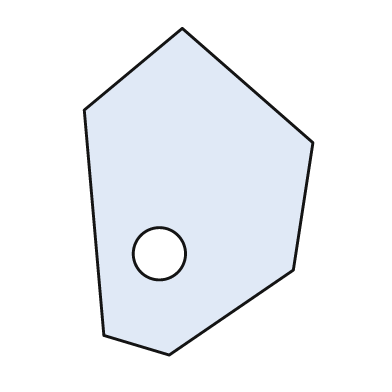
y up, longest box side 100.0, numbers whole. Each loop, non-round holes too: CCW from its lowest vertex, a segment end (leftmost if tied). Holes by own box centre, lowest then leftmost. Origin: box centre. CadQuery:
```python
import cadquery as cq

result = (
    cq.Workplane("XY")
    .moveTo(-9.0, -50.0)
    .lineTo(29.0, -24.0)
    .lineTo(35.0, 15.0)
    .lineTo(-5.0, 50.0)
    .lineTo(-35.0, 25.0)
    .lineTo(-29.0, -44.0)
    .close()
    .moveTo(-12.0, -19.0)
    .circle(8.0)
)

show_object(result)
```